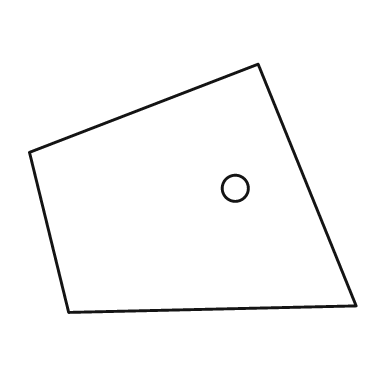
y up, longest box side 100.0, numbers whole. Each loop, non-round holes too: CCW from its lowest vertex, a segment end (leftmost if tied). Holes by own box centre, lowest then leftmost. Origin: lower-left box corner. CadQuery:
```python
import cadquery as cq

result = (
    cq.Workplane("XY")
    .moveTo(12.0, 0.0)
    .lineTo(100.0, 2.0)
    .lineTo(70.0, 76.0)
    .lineTo(0.0, 49.0)
    .close()
    .moveTo(63.0, 38.0)
    .circle(4.0)
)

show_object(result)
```